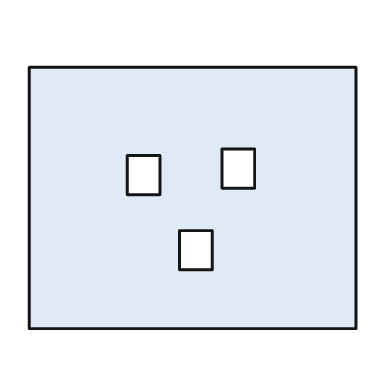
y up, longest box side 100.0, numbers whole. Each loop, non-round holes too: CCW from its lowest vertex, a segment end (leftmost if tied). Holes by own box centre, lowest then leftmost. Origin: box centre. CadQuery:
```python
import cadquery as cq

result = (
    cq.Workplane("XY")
    .moveTo(-50.0, -40.0)
    .lineTo(50.0, -40.0)
    .lineTo(50.0, 40.0)
    .lineTo(-50.0, 40.0)
    .close()
    .moveTo(-4.0, -22.0)
    .lineTo(6.0, -22.0)
    .lineTo(6.0, -10.0)
    .lineTo(-4.0, -10.0)
    .close()
    .moveTo(-20.0, 1.0)
    .lineTo(-10.0, 1.0)
    .lineTo(-10.0, 13.0)
    .lineTo(-20.0, 13.0)
    .close()
    .moveTo(9.0, 3.0)
    .lineTo(19.0, 3.0)
    .lineTo(19.0, 15.0)
    .lineTo(9.0, 15.0)
    .close()
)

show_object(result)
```